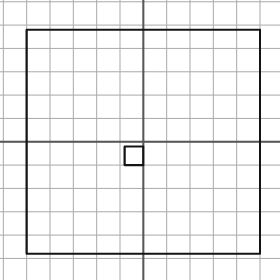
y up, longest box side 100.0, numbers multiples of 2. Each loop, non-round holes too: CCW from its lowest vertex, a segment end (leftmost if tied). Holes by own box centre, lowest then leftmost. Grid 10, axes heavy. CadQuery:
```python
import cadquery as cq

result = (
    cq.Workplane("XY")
    .moveTo(-50.0, -48.0)
    .lineTo(50.0, -48.0)
    .lineTo(50.0, 48.0)
    .lineTo(-50.0, 48.0)
    .close()
    .moveTo(-8.0, -10.0)
    .lineTo(0.0, -10.0)
    .lineTo(0.0, -2.0)
    .lineTo(-8.0, -2.0)
    .close()
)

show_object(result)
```